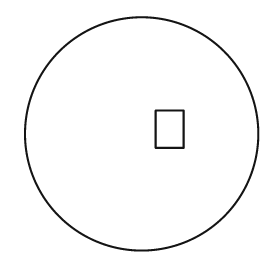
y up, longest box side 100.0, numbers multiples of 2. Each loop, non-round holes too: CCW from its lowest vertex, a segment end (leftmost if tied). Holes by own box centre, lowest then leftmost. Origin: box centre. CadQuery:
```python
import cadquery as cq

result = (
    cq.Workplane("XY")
    .moveTo(0.0, 0.0)
    .circle(50.0)
    .moveTo(6.0, -6.0)
    .lineTo(18.0, -6.0)
    .lineTo(18.0, 10.0)
    .lineTo(6.0, 10.0)
    .close()
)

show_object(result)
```